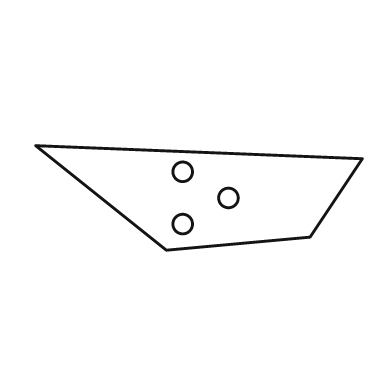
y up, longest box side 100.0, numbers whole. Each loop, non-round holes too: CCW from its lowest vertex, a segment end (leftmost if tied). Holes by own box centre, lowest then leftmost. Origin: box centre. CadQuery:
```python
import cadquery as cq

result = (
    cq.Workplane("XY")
    .moveTo(-10.0, -16.0)
    .lineTo(34.0, -12.0)
    .lineTo(50.0, 12.0)
    .lineTo(-50.0, 16.0)
    .close()
    .moveTo(-5.0, -8.0)
    .circle(3.0)
    .moveTo(9.0, 0.0)
    .circle(3.0)
    .moveTo(-5.0, 8.0)
    .circle(3.0)
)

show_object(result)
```